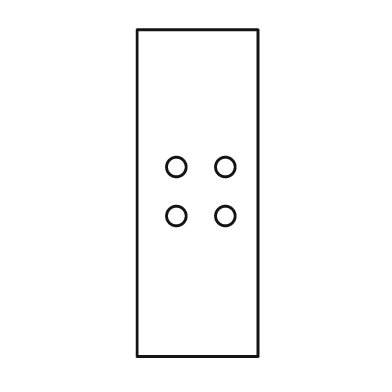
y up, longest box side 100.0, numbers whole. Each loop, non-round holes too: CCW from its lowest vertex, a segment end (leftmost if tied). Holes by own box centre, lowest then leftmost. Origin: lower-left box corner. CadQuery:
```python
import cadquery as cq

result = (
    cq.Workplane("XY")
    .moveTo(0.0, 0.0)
    .lineTo(37.0, 0.0)
    .lineTo(37.0, 100.0)
    .lineTo(0.0, 100.0)
    .close()
    .moveTo(12.0, 43.0)
    .circle(3.0)
    .moveTo(27.0, 43.0)
    .circle(3.0)
    .moveTo(12.0, 58.0)
    .circle(3.0)
    .moveTo(27.0, 58.0)
    .circle(3.0)
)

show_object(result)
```